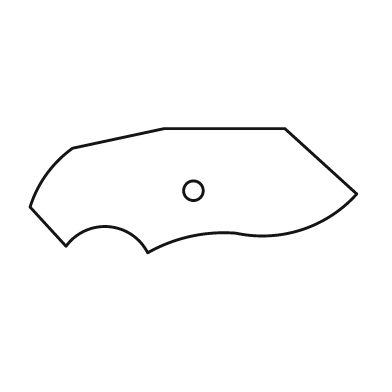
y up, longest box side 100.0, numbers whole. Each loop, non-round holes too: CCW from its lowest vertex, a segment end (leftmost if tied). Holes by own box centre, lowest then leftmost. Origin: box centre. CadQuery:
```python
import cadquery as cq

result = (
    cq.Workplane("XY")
    .moveTo(-14.0, -19.0)
    .threePointArc((-1.0, -14.0), (13.0, -13.0))
    .threePointArc((33.0, -12.0), (50.0, -1.0))
    .lineTo(28.0, 19.0)
    .lineTo(-9.0, 19.0)
    .lineTo(-37.0, 13.0)
    .threePointArc((-45.0, 5.0), (-50.0, -5.0))
    .lineTo(-39.0, -17.0)
    .threePointArc((-26.0, -11.0), (-14.0, -19.0))
    .close()
    .moveTo(0.0, 0.0)
    .circle(3.0)
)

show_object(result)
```